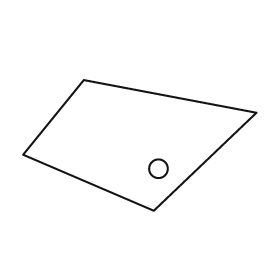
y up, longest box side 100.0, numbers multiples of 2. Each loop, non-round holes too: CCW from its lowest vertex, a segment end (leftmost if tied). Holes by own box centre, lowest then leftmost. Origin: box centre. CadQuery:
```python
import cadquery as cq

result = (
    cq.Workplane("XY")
    .moveTo(6.0, -28.0)
    .lineTo(50.0, 14.0)
    .lineTo(-24.0, 28.0)
    .lineTo(-50.0, -4.0)
    .close()
    .moveTo(8.0, -10.0)
    .circle(4.0)
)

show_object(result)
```